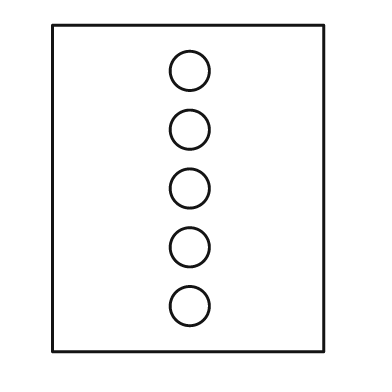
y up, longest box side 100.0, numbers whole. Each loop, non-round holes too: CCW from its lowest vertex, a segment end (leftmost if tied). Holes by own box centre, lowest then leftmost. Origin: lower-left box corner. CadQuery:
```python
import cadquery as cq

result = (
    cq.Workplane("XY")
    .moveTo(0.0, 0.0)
    .lineTo(83.0, 0.0)
    .lineTo(83.0, 100.0)
    .lineTo(0.0, 100.0)
    .close()
    .moveTo(42.0, 14.0)
    .circle(6.0)
    .moveTo(42.0, 32.0)
    .circle(6.0)
    .moveTo(42.0, 50.0)
    .circle(6.0)
    .moveTo(42.0, 68.0)
    .circle(6.0)
    .moveTo(42.0, 86.0)
    .circle(6.0)
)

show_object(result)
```